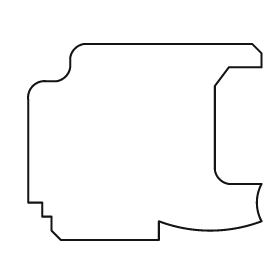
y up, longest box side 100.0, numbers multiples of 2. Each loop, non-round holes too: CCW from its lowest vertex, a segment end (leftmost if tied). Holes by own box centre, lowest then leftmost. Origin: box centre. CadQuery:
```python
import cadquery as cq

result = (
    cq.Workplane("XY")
    .moveTo(-36.0, -42.0)
    .lineTo(6.0, -42.0)
    .lineTo(6.0, -34.0)
    .threePointArc((28.0, -38.0), (50.0, -34.0))
    .threePointArc((48.0, -26.0), (50.0, -18.0))
    .lineTo(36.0, -18.0)
    .threePointArc((32.0, -16.0), (30.0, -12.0))
    .lineTo(30.0, 24.0)
    .lineTo(36.0, 32.0)
    .lineTo(50.0, 32.0)
    .lineTo(50.0, 38.0)
    .lineTo(46.0, 42.0)
    .lineTo(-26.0, 42.0)
    .threePointArc((-30.0, 40.0), (-32.0, 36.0))
    .lineTo(-32.0, 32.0)
    .threePointArc((-34.0, 28.0), (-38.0, 26.0))
    .lineTo(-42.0, 26.0)
    .threePointArc((-48.0, 24.0), (-50.0, 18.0))
    .lineTo(-50.0, -26.0)
    .lineTo(-44.0, -26.0)
    .lineTo(-44.0, -32.0)
    .lineTo(-40.0, -32.0)
    .lineTo(-40.0, -38.0)
    .close()
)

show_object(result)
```